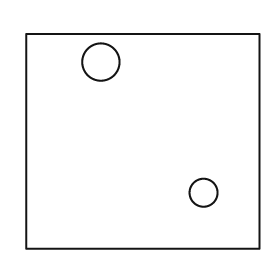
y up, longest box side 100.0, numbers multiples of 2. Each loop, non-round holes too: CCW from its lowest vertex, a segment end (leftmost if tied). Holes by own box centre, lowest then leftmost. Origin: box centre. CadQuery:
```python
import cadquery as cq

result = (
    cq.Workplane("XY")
    .moveTo(-50.0, -46.0)
    .lineTo(50.0, -46.0)
    .lineTo(50.0, 46.0)
    .lineTo(-50.0, 46.0)
    .close()
    .moveTo(26.0, -22.0)
    .circle(6.0)
    .moveTo(-18.0, 34.0)
    .circle(8.0)
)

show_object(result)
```